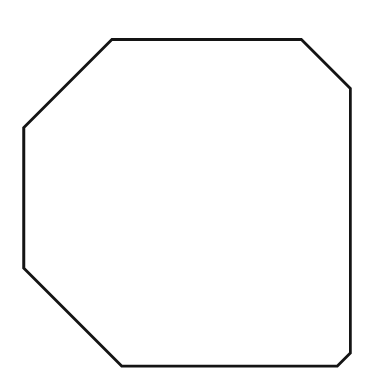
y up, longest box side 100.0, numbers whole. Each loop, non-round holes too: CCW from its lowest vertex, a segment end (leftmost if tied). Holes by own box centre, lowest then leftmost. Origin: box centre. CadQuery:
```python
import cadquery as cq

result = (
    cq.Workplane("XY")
    .moveTo(-20.0, -50.0)
    .lineTo(46.0, -50.0)
    .lineTo(50.0, -46.0)
    .lineTo(50.0, 35.0)
    .lineTo(35.0, 50.0)
    .lineTo(-23.0, 50.0)
    .lineTo(-50.0, 23.0)
    .lineTo(-50.0, -20.0)
    .close()
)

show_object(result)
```